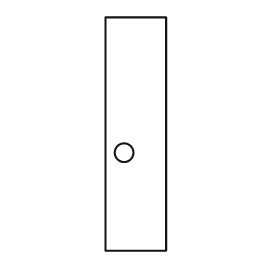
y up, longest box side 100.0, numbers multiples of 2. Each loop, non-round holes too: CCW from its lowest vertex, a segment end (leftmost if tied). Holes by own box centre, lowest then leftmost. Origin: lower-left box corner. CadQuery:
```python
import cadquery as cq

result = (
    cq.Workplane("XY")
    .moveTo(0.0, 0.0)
    .lineTo(26.0, 0.0)
    .lineTo(26.0, 100.0)
    .lineTo(0.0, 100.0)
    .close()
    .moveTo(8.0, 42.0)
    .circle(4.0)
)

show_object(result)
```